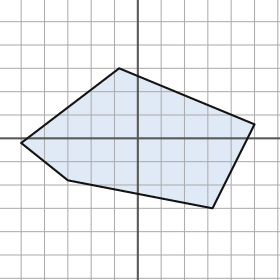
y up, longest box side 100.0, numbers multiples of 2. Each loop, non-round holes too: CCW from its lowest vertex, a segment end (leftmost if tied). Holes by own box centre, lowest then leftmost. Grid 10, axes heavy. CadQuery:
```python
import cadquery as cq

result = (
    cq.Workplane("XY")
    .moveTo(32.0, -30.0)
    .lineTo(50.0, 6.0)
    .lineTo(-8.0, 30.0)
    .lineTo(-50.0, -2.0)
    .lineTo(-30.0, -18.0)
    .close()
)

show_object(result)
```